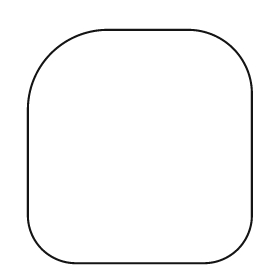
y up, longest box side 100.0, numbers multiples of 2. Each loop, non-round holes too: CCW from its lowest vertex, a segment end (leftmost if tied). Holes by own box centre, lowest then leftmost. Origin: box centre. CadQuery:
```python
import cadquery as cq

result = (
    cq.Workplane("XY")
    .moveTo(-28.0, -50.0)
    .lineTo(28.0, -50.0)
    .threePointArc((42.0, -44.0), (48.0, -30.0))
    .lineTo(48.0, 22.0)
    .threePointArc((40.0, 42.0), (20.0, 50.0))
    .lineTo(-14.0, 50.0)
    .threePointArc((-38.0, 40.0), (-48.0, 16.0))
    .lineTo(-48.0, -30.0)
    .threePointArc((-42.0, -44.0), (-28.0, -50.0))
    .close()
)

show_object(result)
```